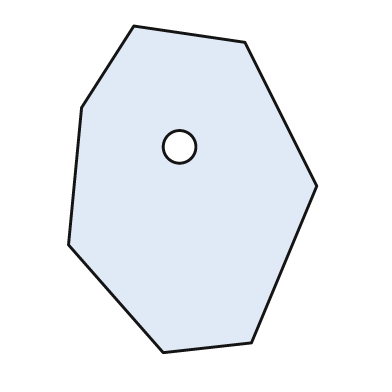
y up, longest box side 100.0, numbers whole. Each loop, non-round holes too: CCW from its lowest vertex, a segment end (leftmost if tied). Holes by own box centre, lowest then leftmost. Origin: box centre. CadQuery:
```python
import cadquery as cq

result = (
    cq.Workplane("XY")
    .moveTo(-9.0, -50.0)
    .lineTo(18.0, -47.0)
    .lineTo(38.0, 1.0)
    .lineTo(16.0, 45.0)
    .lineTo(-18.0, 50.0)
    .lineTo(-34.0, 25.0)
    .lineTo(-38.0, -17.0)
    .close()
    .moveTo(-4.0, 13.0)
    .circle(5.0)
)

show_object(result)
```